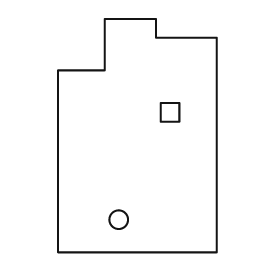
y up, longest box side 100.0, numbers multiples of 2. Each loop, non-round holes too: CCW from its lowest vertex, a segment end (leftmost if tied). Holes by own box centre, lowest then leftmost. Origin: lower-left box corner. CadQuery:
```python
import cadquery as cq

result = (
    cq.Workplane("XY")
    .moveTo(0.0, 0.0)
    .lineTo(68.0, 0.0)
    .lineTo(68.0, 92.0)
    .lineTo(42.0, 92.0)
    .lineTo(42.0, 100.0)
    .lineTo(20.0, 100.0)
    .lineTo(20.0, 78.0)
    .lineTo(0.0, 78.0)
    .close()
    .moveTo(26.0, 14.0)
    .circle(4.0)
    .moveTo(44.0, 56.0)
    .lineTo(52.0, 56.0)
    .lineTo(52.0, 64.0)
    .lineTo(44.0, 64.0)
    .close()
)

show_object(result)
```